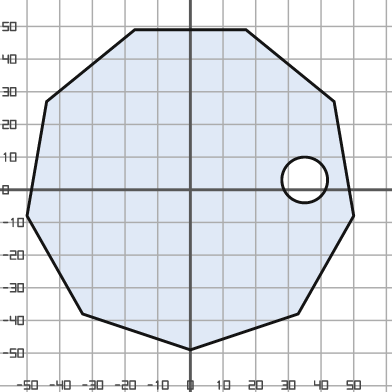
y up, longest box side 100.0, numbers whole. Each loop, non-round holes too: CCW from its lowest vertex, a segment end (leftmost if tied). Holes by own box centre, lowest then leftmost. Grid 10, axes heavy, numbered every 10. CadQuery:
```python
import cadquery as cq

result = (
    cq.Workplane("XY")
    .moveTo(0.0, -49.0)
    .lineTo(33.0, -38.0)
    .lineTo(50.0, -8.0)
    .lineTo(44.0, 27.0)
    .lineTo(17.0, 49.0)
    .lineTo(-17.0, 49.0)
    .lineTo(-44.0, 27.0)
    .lineTo(-50.0, -8.0)
    .lineTo(-33.0, -38.0)
    .close()
    .moveTo(35.0, 3.0)
    .circle(7.0)
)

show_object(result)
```